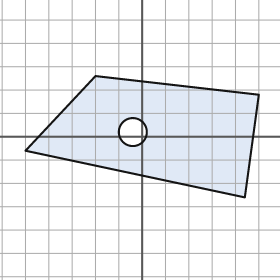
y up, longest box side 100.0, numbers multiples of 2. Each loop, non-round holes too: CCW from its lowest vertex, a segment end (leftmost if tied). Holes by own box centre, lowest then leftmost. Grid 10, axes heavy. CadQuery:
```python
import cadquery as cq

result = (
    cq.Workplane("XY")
    .moveTo(44.0, -26.0)
    .lineTo(50.0, 18.0)
    .lineTo(-20.0, 26.0)
    .lineTo(-50.0, -6.0)
    .close()
    .moveTo(-4.0, 2.0)
    .circle(6.0)
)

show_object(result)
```